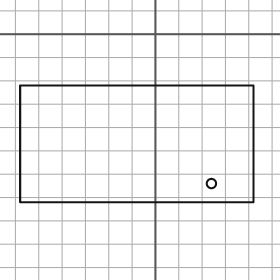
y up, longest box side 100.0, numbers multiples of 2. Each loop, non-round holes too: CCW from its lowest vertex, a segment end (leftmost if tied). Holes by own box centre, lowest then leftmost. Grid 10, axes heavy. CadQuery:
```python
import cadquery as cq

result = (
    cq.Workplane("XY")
    .moveTo(-58.0, -72.0)
    .lineTo(42.0, -72.0)
    .lineTo(42.0, -22.0)
    .lineTo(-58.0, -22.0)
    .close()
    .moveTo(24.0, -64.0)
    .circle(2.0)
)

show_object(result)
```